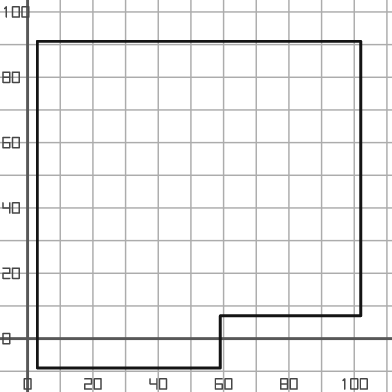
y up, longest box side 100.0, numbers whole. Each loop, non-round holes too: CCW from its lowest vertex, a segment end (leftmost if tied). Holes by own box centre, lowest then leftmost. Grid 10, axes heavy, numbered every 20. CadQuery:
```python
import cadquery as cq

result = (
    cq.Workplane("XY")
    .moveTo(3.0, -9.0)
    .lineTo(59.0, -9.0)
    .lineTo(59.0, 7.0)
    .lineTo(102.0, 7.0)
    .lineTo(102.0, 91.0)
    .lineTo(3.0, 91.0)
    .close()
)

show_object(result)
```